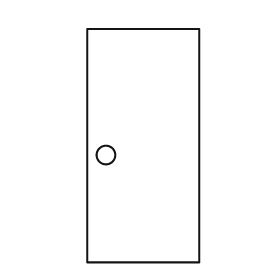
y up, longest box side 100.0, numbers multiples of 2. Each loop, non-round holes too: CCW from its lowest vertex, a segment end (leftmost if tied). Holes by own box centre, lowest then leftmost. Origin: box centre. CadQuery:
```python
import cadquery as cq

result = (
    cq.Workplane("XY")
    .moveTo(-24.0, -50.0)
    .lineTo(24.0, -50.0)
    .lineTo(24.0, 50.0)
    .lineTo(-24.0, 50.0)
    .close()
    .moveTo(-16.0, -4.0)
    .circle(4.0)
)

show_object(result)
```